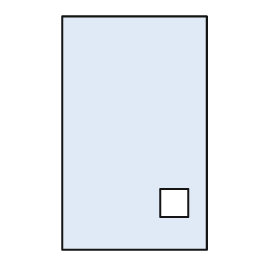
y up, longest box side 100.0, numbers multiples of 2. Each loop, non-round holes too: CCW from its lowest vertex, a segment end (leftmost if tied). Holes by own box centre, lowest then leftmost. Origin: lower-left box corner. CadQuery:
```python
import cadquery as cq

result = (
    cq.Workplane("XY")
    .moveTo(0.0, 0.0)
    .lineTo(62.0, 0.0)
    .lineTo(62.0, 100.0)
    .lineTo(0.0, 100.0)
    .close()
    .moveTo(42.0, 14.0)
    .lineTo(54.0, 14.0)
    .lineTo(54.0, 26.0)
    .lineTo(42.0, 26.0)
    .close()
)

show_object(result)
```